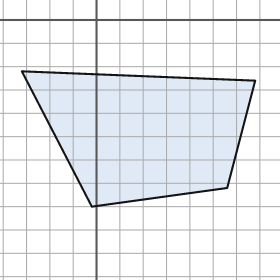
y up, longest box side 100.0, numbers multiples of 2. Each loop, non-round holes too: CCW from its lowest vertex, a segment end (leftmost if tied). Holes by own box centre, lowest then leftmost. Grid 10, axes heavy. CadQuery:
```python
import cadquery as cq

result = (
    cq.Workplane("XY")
    .moveTo(-2.0, -80.0)
    .lineTo(56.0, -72.0)
    .lineTo(68.0, -26.0)
    .lineTo(-32.0, -22.0)
    .close()
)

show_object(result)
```